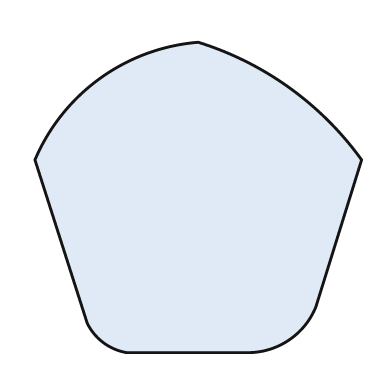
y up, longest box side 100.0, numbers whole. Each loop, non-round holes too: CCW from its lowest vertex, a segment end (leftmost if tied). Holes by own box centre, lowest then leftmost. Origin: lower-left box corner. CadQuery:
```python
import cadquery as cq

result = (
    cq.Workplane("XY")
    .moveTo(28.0, 0.0)
    .lineTo(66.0, 0.0)
    .threePointArc((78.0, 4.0), (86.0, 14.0))
    .lineTo(100.0, 59.0)
    .threePointArc((78.0, 81.0), (50.0, 95.0))
    .threePointArc((20.0, 84.0), (0.0, 59.0))
    .lineTo(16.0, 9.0)
    .threePointArc((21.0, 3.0), (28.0, 0.0))
    .close()
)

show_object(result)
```